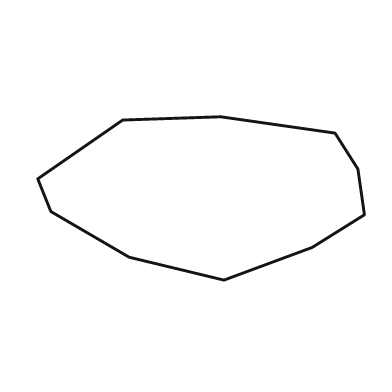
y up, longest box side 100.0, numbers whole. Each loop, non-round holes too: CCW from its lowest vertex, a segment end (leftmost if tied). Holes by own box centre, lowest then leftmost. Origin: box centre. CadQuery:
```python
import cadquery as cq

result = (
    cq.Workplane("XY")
    .moveTo(7.0, -25.0)
    .lineTo(34.0, -15.0)
    .lineTo(50.0, -5.0)
    .lineTo(48.0, 9.0)
    .lineTo(41.0, 20.0)
    .lineTo(6.0, 25.0)
    .lineTo(-24.0, 24.0)
    .lineTo(-50.0, 6.0)
    .lineTo(-46.0, -4.0)
    .lineTo(-22.0, -18.0)
    .close()
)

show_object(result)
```